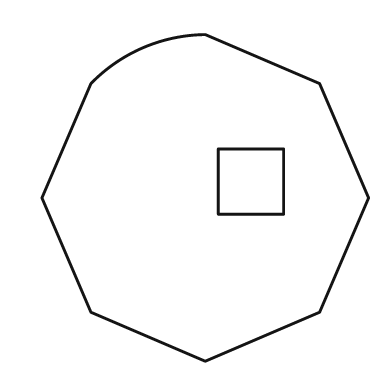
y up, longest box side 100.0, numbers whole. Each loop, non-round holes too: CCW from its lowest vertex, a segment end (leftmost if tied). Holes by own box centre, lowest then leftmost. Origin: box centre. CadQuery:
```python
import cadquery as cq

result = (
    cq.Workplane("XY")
    .moveTo(0.0, -50.0)
    .lineTo(35.0, -35.0)
    .lineTo(50.0, 0.0)
    .lineTo(35.0, 35.0)
    .lineTo(0.0, 50.0)
    .threePointArc((-19.0, 46.0), (-35.0, 35.0))
    .lineTo(-50.0, 0.0)
    .lineTo(-35.0, -35.0)
    .close()
    .moveTo(4.0, -5.0)
    .lineTo(24.0, -5.0)
    .lineTo(24.0, 15.0)
    .lineTo(4.0, 15.0)
    .close()
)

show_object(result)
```